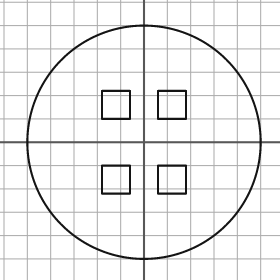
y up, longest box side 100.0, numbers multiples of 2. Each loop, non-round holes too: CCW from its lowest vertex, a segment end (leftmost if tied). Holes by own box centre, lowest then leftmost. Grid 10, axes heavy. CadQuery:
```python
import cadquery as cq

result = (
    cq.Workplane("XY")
    .moveTo(0.0, 0.0)
    .circle(50.0)
    .moveTo(-18.0, -22.0)
    .lineTo(-6.0, -22.0)
    .lineTo(-6.0, -10.0)
    .lineTo(-18.0, -10.0)
    .close()
    .moveTo(6.0, -22.0)
    .lineTo(18.0, -22.0)
    .lineTo(18.0, -10.0)
    .lineTo(6.0, -10.0)
    .close()
    .moveTo(-18.0, 10.0)
    .lineTo(-6.0, 10.0)
    .lineTo(-6.0, 22.0)
    .lineTo(-18.0, 22.0)
    .close()
    .moveTo(6.0, 10.0)
    .lineTo(18.0, 10.0)
    .lineTo(18.0, 22.0)
    .lineTo(6.0, 22.0)
    .close()
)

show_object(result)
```